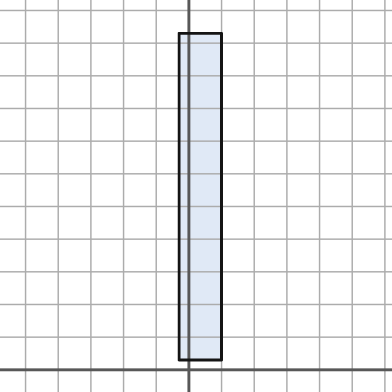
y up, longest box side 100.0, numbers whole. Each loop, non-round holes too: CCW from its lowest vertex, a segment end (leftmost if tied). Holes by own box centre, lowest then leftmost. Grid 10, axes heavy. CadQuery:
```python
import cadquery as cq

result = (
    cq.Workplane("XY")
    .moveTo(-3.0, 3.0)
    .lineTo(10.0, 3.0)
    .lineTo(10.0, 103.0)
    .lineTo(-3.0, 103.0)
    .close()
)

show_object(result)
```